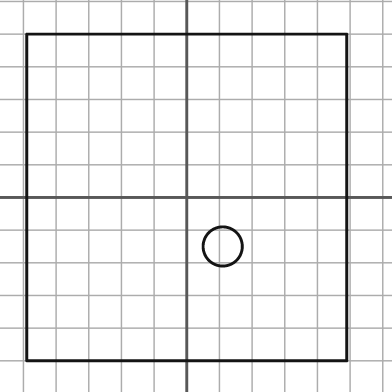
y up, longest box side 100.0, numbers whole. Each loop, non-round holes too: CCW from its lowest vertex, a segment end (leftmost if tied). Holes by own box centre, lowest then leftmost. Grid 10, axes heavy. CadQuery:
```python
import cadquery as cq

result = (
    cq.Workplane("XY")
    .moveTo(-49.0, -50.0)
    .lineTo(49.0, -50.0)
    .lineTo(49.0, 50.0)
    .lineTo(-49.0, 50.0)
    .close()
    .moveTo(11.0, -15.0)
    .circle(6.0)
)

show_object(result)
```